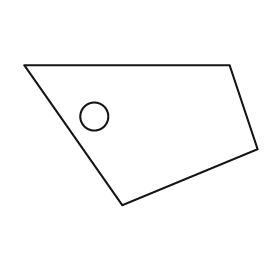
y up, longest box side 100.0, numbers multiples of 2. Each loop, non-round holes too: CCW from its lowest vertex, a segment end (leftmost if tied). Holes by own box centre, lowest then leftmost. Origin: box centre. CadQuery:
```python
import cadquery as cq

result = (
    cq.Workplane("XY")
    .moveTo(-8.0, -30.0)
    .lineTo(50.0, -6.0)
    .lineTo(38.0, 30.0)
    .lineTo(-50.0, 30.0)
    .close()
    .moveTo(-20.0, 8.0)
    .circle(6.0)
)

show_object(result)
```